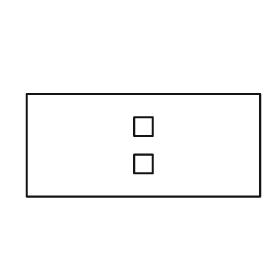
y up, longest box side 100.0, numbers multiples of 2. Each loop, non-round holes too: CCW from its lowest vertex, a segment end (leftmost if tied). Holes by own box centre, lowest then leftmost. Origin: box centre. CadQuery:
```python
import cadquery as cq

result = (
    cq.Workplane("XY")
    .moveTo(-50.0, -22.0)
    .lineTo(50.0, -22.0)
    .lineTo(50.0, 22.0)
    .lineTo(-50.0, 22.0)
    .close()
    .moveTo(-4.0, -12.0)
    .lineTo(4.0, -12.0)
    .lineTo(4.0, -4.0)
    .lineTo(-4.0, -4.0)
    .close()
    .moveTo(-4.0, 4.0)
    .lineTo(4.0, 4.0)
    .lineTo(4.0, 12.0)
    .lineTo(-4.0, 12.0)
    .close()
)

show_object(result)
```